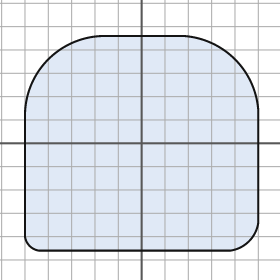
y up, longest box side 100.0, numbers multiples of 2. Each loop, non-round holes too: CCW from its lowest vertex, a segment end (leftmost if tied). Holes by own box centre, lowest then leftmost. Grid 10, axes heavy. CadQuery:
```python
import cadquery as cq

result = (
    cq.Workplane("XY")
    .moveTo(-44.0, -46.0)
    .lineTo(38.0, -46.0)
    .threePointArc((46.0, -42.0), (50.0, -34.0))
    .lineTo(50.0, 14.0)
    .threePointArc((40.0, 36.0), (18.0, 46.0))
    .lineTo(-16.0, 46.0)
    .threePointArc((-40.0, 36.0), (-50.0, 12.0))
    .lineTo(-50.0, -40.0)
    .threePointArc((-48.0, -44.0), (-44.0, -46.0))
    .close()
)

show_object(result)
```